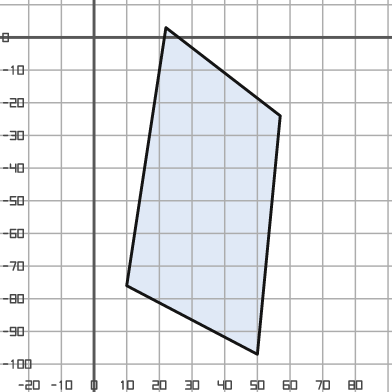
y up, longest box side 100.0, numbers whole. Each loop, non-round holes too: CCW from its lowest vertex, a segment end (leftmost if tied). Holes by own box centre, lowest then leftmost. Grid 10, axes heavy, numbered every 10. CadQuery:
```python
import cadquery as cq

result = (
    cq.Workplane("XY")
    .moveTo(50.0, -97.0)
    .lineTo(57.0, -24.0)
    .lineTo(22.0, 3.0)
    .lineTo(10.0, -76.0)
    .close()
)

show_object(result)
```